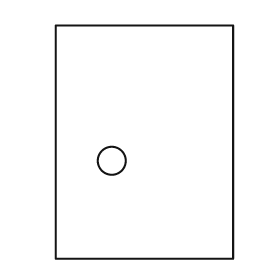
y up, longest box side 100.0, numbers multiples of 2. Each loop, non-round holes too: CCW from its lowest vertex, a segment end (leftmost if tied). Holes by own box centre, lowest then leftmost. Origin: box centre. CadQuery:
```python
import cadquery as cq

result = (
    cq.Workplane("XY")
    .moveTo(-38.0, -50.0)
    .lineTo(38.0, -50.0)
    .lineTo(38.0, 50.0)
    .lineTo(-38.0, 50.0)
    .close()
    .moveTo(-14.0, -8.0)
    .circle(6.0)
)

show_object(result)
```